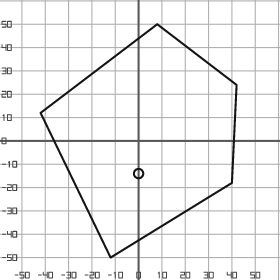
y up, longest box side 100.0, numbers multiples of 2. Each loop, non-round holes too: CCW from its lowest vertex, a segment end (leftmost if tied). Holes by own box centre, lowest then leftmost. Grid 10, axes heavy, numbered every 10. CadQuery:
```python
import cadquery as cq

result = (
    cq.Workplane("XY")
    .moveTo(-12.0, -50.0)
    .lineTo(40.0, -18.0)
    .lineTo(42.0, 24.0)
    .lineTo(8.0, 50.0)
    .lineTo(-42.0, 12.0)
    .close()
    .moveTo(0.0, -14.0)
    .circle(2.0)
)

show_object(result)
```